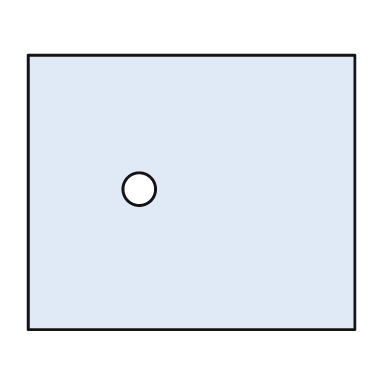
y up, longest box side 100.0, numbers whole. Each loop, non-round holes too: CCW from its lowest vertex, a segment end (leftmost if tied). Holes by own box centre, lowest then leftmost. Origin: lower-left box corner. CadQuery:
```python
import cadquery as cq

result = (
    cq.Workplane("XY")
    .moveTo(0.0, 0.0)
    .lineTo(100.0, 0.0)
    .lineTo(100.0, 84.0)
    .lineTo(0.0, 84.0)
    .close()
    .moveTo(34.0, 43.0)
    .circle(5.0)
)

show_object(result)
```